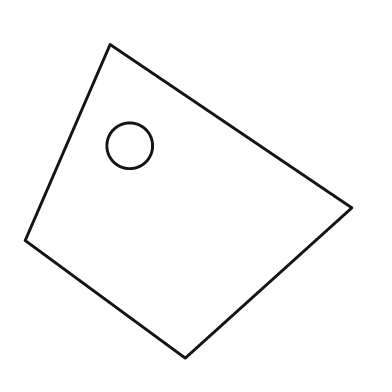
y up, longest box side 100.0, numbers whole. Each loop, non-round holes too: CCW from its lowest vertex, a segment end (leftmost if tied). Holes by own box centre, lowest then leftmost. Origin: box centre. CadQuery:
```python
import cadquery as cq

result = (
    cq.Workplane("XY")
    .moveTo(-1.0, -48.0)
    .lineTo(50.0, -2.0)
    .lineTo(-24.0, 48.0)
    .lineTo(-50.0, -12.0)
    .close()
    .moveTo(-18.0, 17.0)
    .circle(7.0)
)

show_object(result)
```